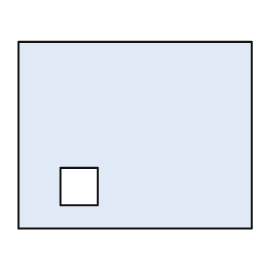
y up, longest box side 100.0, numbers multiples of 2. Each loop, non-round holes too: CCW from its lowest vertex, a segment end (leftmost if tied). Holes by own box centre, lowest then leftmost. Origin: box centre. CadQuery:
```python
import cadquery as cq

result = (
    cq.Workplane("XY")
    .moveTo(-50.0, -40.0)
    .lineTo(50.0, -40.0)
    .lineTo(50.0, 40.0)
    .lineTo(-50.0, 40.0)
    .close()
    .moveTo(-32.0, -30.0)
    .lineTo(-16.0, -30.0)
    .lineTo(-16.0, -14.0)
    .lineTo(-32.0, -14.0)
    .close()
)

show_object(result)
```